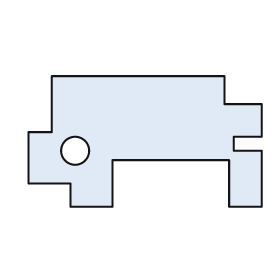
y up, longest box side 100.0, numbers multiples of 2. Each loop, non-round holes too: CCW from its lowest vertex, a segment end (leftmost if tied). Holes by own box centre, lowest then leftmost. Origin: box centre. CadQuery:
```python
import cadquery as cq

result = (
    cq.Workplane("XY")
    .moveTo(-32.0, -28.0)
    .lineTo(-14.0, -28.0)
    .lineTo(-14.0, -8.0)
    .lineTo(36.0, -8.0)
    .lineTo(36.0, -28.0)
    .lineTo(50.0, -28.0)
    .lineTo(50.0, -4.0)
    .lineTo(38.0, -4.0)
    .lineTo(38.0, 2.0)
    .lineTo(50.0, 2.0)
    .lineTo(50.0, 16.0)
    .lineTo(34.0, 16.0)
    .lineTo(34.0, 28.0)
    .lineTo(-40.0, 28.0)
    .lineTo(-40.0, 4.0)
    .lineTo(-50.0, 4.0)
    .lineTo(-50.0, -18.0)
    .lineTo(-32.0, -18.0)
    .close()
    .moveTo(-30.0, -4.0)
    .circle(6.0)
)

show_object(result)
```